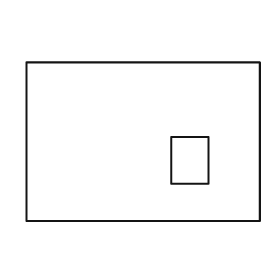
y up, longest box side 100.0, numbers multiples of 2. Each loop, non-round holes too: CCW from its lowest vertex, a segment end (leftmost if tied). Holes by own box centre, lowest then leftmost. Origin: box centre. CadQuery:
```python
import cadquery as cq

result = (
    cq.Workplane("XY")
    .moveTo(-50.0, -34.0)
    .lineTo(50.0, -34.0)
    .lineTo(50.0, 34.0)
    .lineTo(-50.0, 34.0)
    .close()
    .moveTo(12.0, -18.0)
    .lineTo(28.0, -18.0)
    .lineTo(28.0, 2.0)
    .lineTo(12.0, 2.0)
    .close()
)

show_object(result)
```